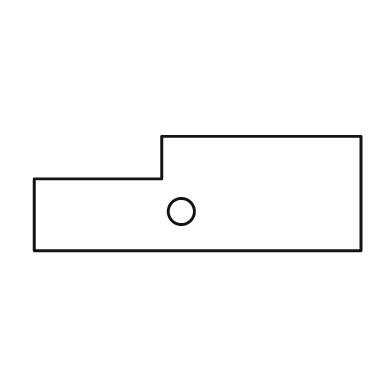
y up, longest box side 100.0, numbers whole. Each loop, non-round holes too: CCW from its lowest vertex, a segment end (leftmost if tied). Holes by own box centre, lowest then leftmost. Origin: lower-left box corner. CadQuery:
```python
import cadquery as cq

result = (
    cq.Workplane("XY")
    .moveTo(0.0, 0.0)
    .lineTo(100.0, 0.0)
    .lineTo(100.0, 35.0)
    .lineTo(39.0, 35.0)
    .lineTo(39.0, 22.0)
    .lineTo(0.0, 22.0)
    .close()
    .moveTo(45.0, 12.0)
    .circle(4.0)
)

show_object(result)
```